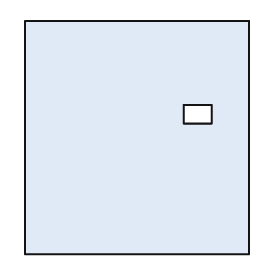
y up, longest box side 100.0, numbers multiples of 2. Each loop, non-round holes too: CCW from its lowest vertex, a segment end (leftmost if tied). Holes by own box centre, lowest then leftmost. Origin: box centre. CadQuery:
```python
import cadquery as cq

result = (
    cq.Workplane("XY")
    .moveTo(-48.0, -50.0)
    .lineTo(48.0, -50.0)
    .lineTo(48.0, 50.0)
    .lineTo(-48.0, 50.0)
    .close()
    .moveTo(20.0, 6.0)
    .lineTo(32.0, 6.0)
    .lineTo(32.0, 14.0)
    .lineTo(20.0, 14.0)
    .close()
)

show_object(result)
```